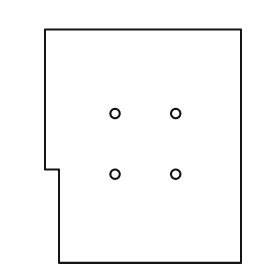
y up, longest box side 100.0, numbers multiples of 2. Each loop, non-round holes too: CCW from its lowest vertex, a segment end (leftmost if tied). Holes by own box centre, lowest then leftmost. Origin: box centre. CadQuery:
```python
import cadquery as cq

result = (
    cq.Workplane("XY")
    .moveTo(-36.0, -50.0)
    .lineTo(42.0, -50.0)
    .lineTo(42.0, 50.0)
    .lineTo(-42.0, 50.0)
    .lineTo(-42.0, -10.0)
    .lineTo(-36.0, -10.0)
    .close()
    .moveTo(-12.0, -12.0)
    .circle(2.0)
    .moveTo(14.0, -12.0)
    .circle(2.0)
    .moveTo(-12.0, 14.0)
    .circle(2.0)
    .moveTo(14.0, 14.0)
    .circle(2.0)
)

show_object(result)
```